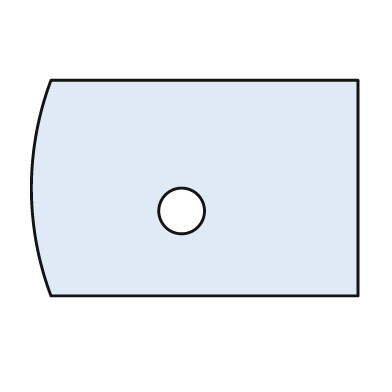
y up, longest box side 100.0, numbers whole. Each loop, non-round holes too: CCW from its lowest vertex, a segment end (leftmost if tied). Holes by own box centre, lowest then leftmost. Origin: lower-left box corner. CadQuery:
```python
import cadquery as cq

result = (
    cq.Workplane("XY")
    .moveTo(6.0, 0.0)
    .lineTo(100.0, 0.0)
    .lineTo(100.0, 66.0)
    .lineTo(6.0, 66.0)
    .threePointArc((0.0, 33.0), (6.0, 0.0))
    .close()
    .moveTo(46.0, 26.0)
    .circle(7.0)
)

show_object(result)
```